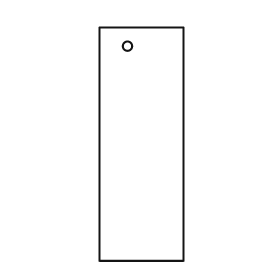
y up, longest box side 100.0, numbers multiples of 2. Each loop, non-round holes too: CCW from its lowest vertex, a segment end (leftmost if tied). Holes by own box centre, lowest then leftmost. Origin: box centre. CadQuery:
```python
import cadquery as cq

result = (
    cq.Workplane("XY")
    .moveTo(-18.0, -50.0)
    .lineTo(18.0, -50.0)
    .lineTo(18.0, 50.0)
    .lineTo(-18.0, 50.0)
    .close()
    .moveTo(-6.0, 42.0)
    .circle(2.0)
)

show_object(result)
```